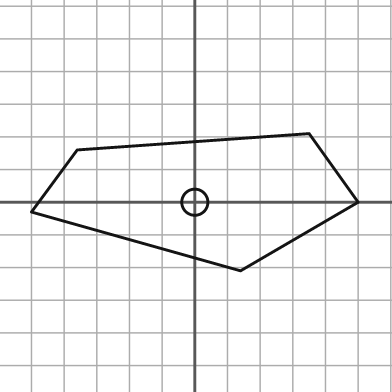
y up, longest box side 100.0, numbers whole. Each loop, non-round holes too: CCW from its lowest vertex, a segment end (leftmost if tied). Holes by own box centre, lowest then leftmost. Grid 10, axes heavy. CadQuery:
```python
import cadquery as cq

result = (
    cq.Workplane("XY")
    .moveTo(14.0, -21.0)
    .lineTo(50.0, 0.0)
    .lineTo(35.0, 21.0)
    .lineTo(-36.0, 16.0)
    .lineTo(-50.0, -3.0)
    .close()
    .moveTo(0.0, 0.0)
    .circle(4.0)
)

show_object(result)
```